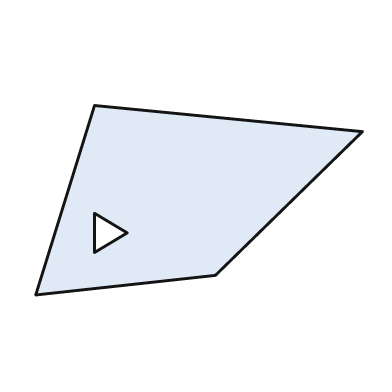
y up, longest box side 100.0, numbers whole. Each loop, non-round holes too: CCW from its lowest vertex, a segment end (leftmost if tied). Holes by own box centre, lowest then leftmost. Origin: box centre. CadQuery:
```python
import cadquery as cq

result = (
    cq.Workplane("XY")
    .moveTo(-50.0, -29.0)
    .lineTo(5.0, -23.0)
    .lineTo(50.0, 21.0)
    .lineTo(-32.0, 29.0)
    .close()
    .moveTo(-32.0, -16.0)
    .lineTo(-22.0, -10.0)
    .lineTo(-32.0, -4.0)
    .close()
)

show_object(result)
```